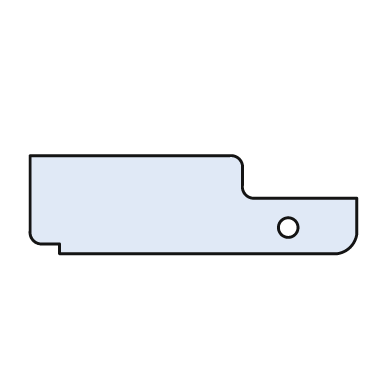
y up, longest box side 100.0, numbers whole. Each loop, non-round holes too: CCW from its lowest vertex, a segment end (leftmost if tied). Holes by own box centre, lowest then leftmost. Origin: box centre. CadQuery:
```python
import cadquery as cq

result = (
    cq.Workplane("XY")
    .moveTo(-41.0, -15.0)
    .lineTo(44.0, -15.0)
    .threePointArc((48.0, -13.0), (50.0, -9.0))
    .lineTo(50.0, 2.0)
    .lineTo(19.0, 2.0)
    .threePointArc((16.0, 3.0), (15.0, 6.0))
    .lineTo(15.0, 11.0)
    .threePointArc((14.0, 14.0), (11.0, 15.0))
    .lineTo(-50.0, 15.0)
    .lineTo(-50.0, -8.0)
    .threePointArc((-49.0, -11.0), (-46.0, -12.0))
    .lineTo(-41.0, -12.0)
    .close()
    .moveTo(29.0, -7.0)
    .circle(3.0)
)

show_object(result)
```